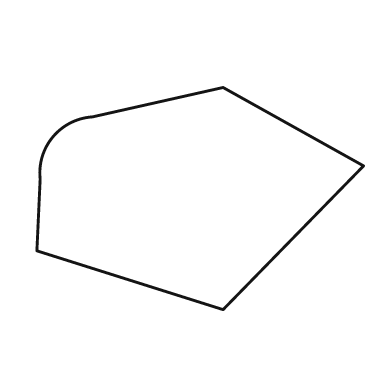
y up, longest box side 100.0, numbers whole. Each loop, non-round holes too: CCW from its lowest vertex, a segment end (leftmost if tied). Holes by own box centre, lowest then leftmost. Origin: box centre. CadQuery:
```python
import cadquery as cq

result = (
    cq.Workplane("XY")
    .moveTo(7.0, -34.0)
    .lineTo(50.0, 10.0)
    .lineTo(7.0, 34.0)
    .lineTo(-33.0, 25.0)
    .threePointArc((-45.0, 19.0), (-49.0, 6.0))
    .lineTo(-50.0, -16.0)
    .close()
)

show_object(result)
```